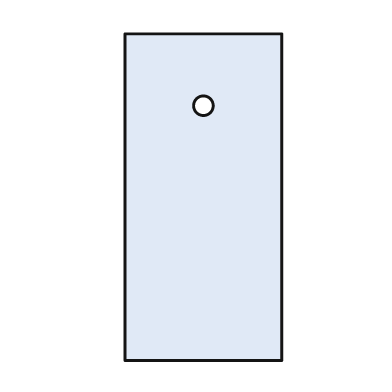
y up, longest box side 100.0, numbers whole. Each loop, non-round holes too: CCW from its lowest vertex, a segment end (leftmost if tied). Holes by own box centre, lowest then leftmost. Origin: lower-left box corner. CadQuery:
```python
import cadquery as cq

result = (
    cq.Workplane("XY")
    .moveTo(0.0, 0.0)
    .lineTo(48.0, 0.0)
    .lineTo(48.0, 100.0)
    .lineTo(0.0, 100.0)
    .close()
    .moveTo(24.0, 78.0)
    .circle(3.0)
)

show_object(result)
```